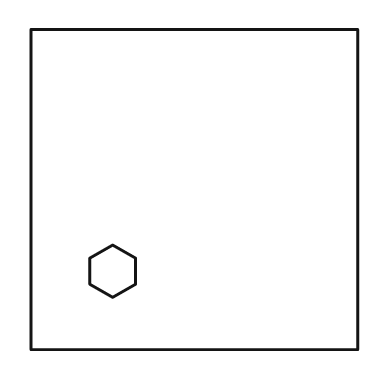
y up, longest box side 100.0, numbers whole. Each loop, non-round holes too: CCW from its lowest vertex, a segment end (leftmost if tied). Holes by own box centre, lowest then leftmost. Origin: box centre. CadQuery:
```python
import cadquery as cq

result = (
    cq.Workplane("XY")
    .moveTo(-50.0, -49.0)
    .lineTo(50.0, -49.0)
    .lineTo(50.0, 49.0)
    .lineTo(-50.0, 49.0)
    .close()
    .moveTo(-25.0, -33.0)
    .lineTo(-18.0, -29.0)
    .lineTo(-18.0, -21.0)
    .lineTo(-25.0, -17.0)
    .lineTo(-32.0, -21.0)
    .lineTo(-32.0, -29.0)
    .close()
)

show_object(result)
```